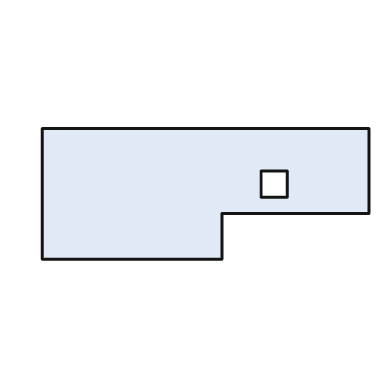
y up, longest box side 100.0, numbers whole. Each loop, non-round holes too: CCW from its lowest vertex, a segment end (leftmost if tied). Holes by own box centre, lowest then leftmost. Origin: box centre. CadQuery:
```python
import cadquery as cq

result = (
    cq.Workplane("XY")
    .moveTo(-50.0, -20.0)
    .lineTo(5.0, -20.0)
    .lineTo(5.0, -6.0)
    .lineTo(50.0, -6.0)
    .lineTo(50.0, 20.0)
    .lineTo(-50.0, 20.0)
    .close()
    .moveTo(17.0, -1.0)
    .lineTo(25.0, -1.0)
    .lineTo(25.0, 7.0)
    .lineTo(17.0, 7.0)
    .close()
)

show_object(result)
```